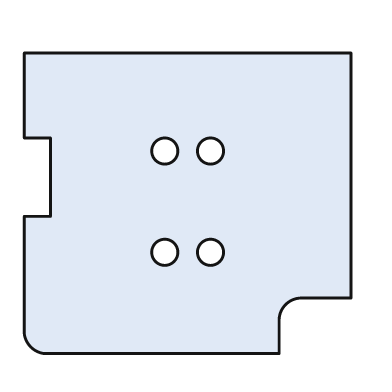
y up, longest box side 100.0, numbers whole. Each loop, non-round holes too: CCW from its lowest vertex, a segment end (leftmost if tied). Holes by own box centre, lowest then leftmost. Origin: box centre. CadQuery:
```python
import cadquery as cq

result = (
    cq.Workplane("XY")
    .moveTo(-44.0, -46.0)
    .lineTo(28.0, -46.0)
    .lineTo(28.0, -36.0)
    .threePointArc((30.0, -31.0), (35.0, -29.0))
    .lineTo(50.0, -29.0)
    .lineTo(50.0, 46.0)
    .lineTo(-50.0, 46.0)
    .lineTo(-50.0, 20.0)
    .lineTo(-42.0, 20.0)
    .lineTo(-42.0, -4.0)
    .lineTo(-50.0, -4.0)
    .lineTo(-50.0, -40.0)
    .threePointArc((-48.0, -44.0), (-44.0, -46.0))
    .close()
    .moveTo(-7.0, -15.0)
    .circle(4.0)
    .moveTo(7.0, -15.0)
    .circle(4.0)
    .moveTo(-7.0, 16.0)
    .circle(4.0)
    .moveTo(7.0, 16.0)
    .circle(4.0)
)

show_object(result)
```